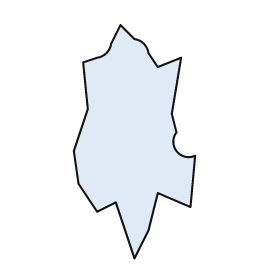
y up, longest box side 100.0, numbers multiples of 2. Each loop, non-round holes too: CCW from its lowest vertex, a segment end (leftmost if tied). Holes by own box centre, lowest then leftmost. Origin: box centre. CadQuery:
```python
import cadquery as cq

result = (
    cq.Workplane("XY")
    .moveTo(0.0, -50.0)
    .lineTo(6.0, -38.0)
    .lineTo(10.0, -22.0)
    .lineTo(24.0, -28.0)
    .lineTo(26.0, -6.0)
    .threePointArc((18.0, -4.0), (18.0, 4.0))
    .lineTo(16.0, 12.0)
    .lineTo(20.0, 36.0)
    .lineTo(10.0, 32.0)
    .lineTo(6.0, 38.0)
    .threePointArc((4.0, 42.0), (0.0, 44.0))
    .lineTo(-6.0, 50.0)
    .lineTo(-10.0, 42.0)
    .threePointArc((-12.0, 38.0), (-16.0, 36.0))
    .lineTo(-22.0, 34.0)
    .lineTo(-20.0, 14.0)
    .lineTo(-26.0, -4.0)
    .lineTo(-24.0, -18.0)
    .lineTo(-16.0, -30.0)
    .lineTo(-8.0, -26.0)
    .close()
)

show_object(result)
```